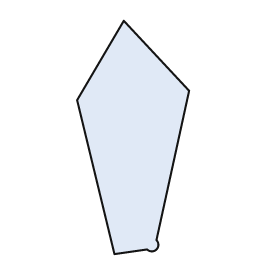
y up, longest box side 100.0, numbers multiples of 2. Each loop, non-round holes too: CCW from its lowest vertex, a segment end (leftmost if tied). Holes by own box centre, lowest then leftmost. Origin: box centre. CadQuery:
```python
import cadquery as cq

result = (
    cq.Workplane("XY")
    .moveTo(-8.0, -50.0)
    .lineTo(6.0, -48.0)
    .threePointArc((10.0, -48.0), (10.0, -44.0))
    .lineTo(24.0, 20.0)
    .lineTo(-4.0, 50.0)
    .lineTo(-24.0, 16.0)
    .close()
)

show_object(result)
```